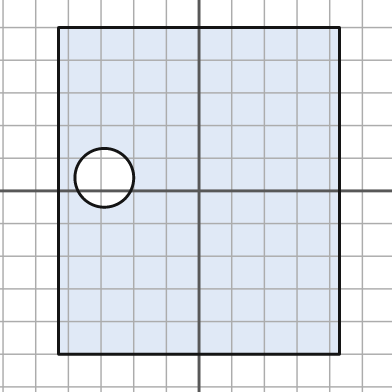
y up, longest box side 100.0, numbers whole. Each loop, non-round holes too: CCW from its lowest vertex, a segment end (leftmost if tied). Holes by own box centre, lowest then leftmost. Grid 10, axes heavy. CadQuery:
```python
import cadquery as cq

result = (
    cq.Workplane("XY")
    .moveTo(-43.0, -50.0)
    .lineTo(43.0, -50.0)
    .lineTo(43.0, 50.0)
    .lineTo(-43.0, 50.0)
    .close()
    .moveTo(-29.0, 4.0)
    .circle(9.0)
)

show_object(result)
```